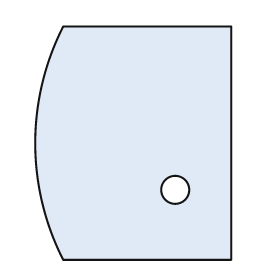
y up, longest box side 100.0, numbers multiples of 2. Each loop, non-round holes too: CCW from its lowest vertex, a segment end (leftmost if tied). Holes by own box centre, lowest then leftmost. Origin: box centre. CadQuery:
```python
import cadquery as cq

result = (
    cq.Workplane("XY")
    .moveTo(-30.0, -50.0)
    .lineTo(42.0, -50.0)
    .lineTo(42.0, 50.0)
    .lineTo(-30.0, 50.0)
    .threePointArc((-42.0, 0.0), (-30.0, -50.0))
    .close()
    .moveTo(18.0, -20.0)
    .circle(6.0)
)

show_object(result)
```